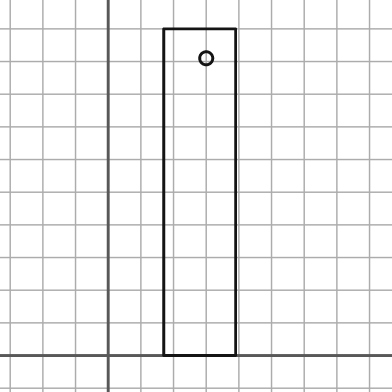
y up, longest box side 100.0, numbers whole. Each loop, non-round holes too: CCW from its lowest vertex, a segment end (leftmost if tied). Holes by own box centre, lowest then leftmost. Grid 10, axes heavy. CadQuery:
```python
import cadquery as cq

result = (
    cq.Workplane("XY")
    .moveTo(17.0, 0.0)
    .lineTo(39.0, 0.0)
    .lineTo(39.0, 100.0)
    .lineTo(17.0, 100.0)
    .close()
    .moveTo(30.0, 91.0)
    .circle(2.0)
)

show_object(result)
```